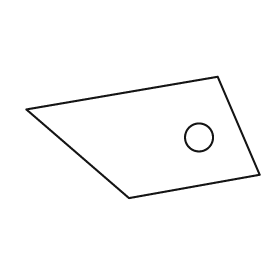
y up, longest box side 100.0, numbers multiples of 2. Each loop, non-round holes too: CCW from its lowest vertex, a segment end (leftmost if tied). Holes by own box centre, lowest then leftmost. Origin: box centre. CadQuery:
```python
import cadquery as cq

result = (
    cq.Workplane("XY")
    .moveTo(-6.0, -26.0)
    .lineTo(50.0, -16.0)
    .lineTo(32.0, 26.0)
    .lineTo(-50.0, 12.0)
    .close()
    .moveTo(24.0, 0.0)
    .circle(6.0)
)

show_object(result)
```